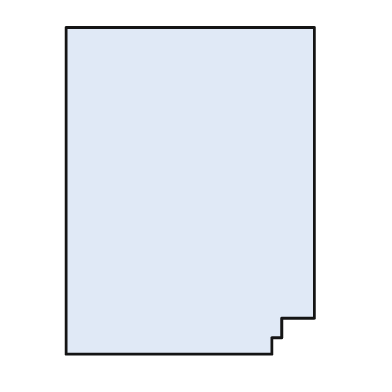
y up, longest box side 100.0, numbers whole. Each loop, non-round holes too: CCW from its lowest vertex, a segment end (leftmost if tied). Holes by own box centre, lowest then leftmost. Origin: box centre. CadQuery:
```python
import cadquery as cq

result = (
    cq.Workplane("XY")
    .moveTo(-38.0, -50.0)
    .lineTo(25.0, -50.0)
    .lineTo(25.0, -45.0)
    .lineTo(28.0, -45.0)
    .lineTo(28.0, -39.0)
    .lineTo(38.0, -39.0)
    .lineTo(38.0, 50.0)
    .lineTo(-38.0, 50.0)
    .close()
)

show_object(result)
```